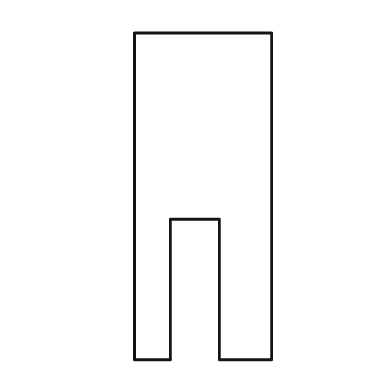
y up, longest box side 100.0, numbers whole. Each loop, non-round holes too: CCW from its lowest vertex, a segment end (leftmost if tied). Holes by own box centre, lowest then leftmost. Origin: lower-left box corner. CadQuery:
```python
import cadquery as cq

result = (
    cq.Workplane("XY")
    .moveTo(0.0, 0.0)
    .lineTo(11.0, 0.0)
    .lineTo(11.0, 43.0)
    .lineTo(26.0, 43.0)
    .lineTo(26.0, 0.0)
    .lineTo(42.0, 0.0)
    .lineTo(42.0, 100.0)
    .lineTo(0.0, 100.0)
    .close()
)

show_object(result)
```